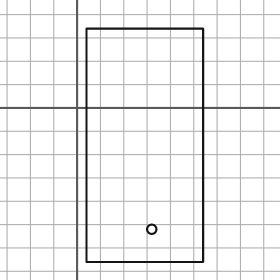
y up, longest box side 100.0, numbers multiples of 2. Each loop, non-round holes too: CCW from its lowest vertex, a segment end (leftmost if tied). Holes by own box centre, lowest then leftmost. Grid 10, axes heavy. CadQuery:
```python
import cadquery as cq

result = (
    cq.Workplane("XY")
    .moveTo(4.0, -66.0)
    .lineTo(54.0, -66.0)
    .lineTo(54.0, 34.0)
    .lineTo(4.0, 34.0)
    .close()
    .moveTo(32.0, -52.0)
    .circle(2.0)
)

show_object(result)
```